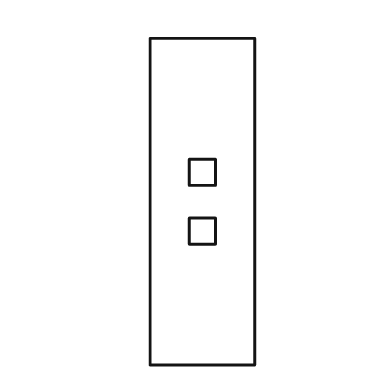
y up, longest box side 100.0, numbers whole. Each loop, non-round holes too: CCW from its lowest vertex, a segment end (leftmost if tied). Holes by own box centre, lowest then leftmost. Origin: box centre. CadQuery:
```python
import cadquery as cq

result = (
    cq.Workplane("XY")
    .moveTo(-16.0, -50.0)
    .lineTo(16.0, -50.0)
    .lineTo(16.0, 50.0)
    .lineTo(-16.0, 50.0)
    .close()
    .moveTo(-4.0, -13.0)
    .lineTo(4.0, -13.0)
    .lineTo(4.0, -5.0)
    .lineTo(-4.0, -5.0)
    .close()
    .moveTo(-4.0, 5.0)
    .lineTo(4.0, 5.0)
    .lineTo(4.0, 13.0)
    .lineTo(-4.0, 13.0)
    .close()
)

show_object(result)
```